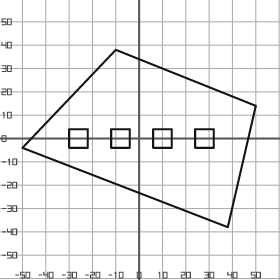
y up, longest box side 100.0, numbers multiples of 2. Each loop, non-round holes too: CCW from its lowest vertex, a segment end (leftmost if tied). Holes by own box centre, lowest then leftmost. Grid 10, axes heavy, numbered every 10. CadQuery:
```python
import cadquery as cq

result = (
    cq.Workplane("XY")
    .moveTo(38.0, -38.0)
    .lineTo(50.0, 14.0)
    .lineTo(-10.0, 38.0)
    .lineTo(-50.0, -4.0)
    .close()
    .moveTo(-30.0, -4.0)
    .lineTo(-22.0, -4.0)
    .lineTo(-22.0, 4.0)
    .lineTo(-30.0, 4.0)
    .close()
    .moveTo(-12.0, -4.0)
    .lineTo(-4.0, -4.0)
    .lineTo(-4.0, 4.0)
    .lineTo(-12.0, 4.0)
    .close()
    .moveTo(6.0, -4.0)
    .lineTo(14.0, -4.0)
    .lineTo(14.0, 4.0)
    .lineTo(6.0, 4.0)
    .close()
    .moveTo(24.0, -4.0)
    .lineTo(32.0, -4.0)
    .lineTo(32.0, 4.0)
    .lineTo(24.0, 4.0)
    .close()
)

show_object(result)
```